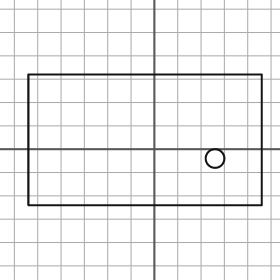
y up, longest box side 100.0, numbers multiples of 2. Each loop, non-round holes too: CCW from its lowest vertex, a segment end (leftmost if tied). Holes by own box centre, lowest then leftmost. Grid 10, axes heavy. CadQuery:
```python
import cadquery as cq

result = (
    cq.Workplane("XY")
    .moveTo(-54.0, -24.0)
    .lineTo(46.0, -24.0)
    .lineTo(46.0, 32.0)
    .lineTo(-54.0, 32.0)
    .close()
    .moveTo(26.0, -4.0)
    .circle(4.0)
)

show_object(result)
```